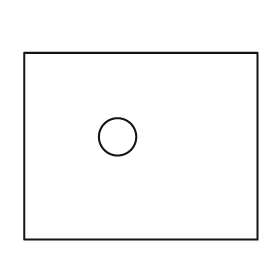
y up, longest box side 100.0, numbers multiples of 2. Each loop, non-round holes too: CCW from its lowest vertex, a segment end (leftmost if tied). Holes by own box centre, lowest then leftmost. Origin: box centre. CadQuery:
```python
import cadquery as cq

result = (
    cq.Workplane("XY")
    .moveTo(-50.0, -40.0)
    .lineTo(50.0, -40.0)
    .lineTo(50.0, 40.0)
    .lineTo(-50.0, 40.0)
    .close()
    .moveTo(-10.0, 4.0)
    .circle(8.0)
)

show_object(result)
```